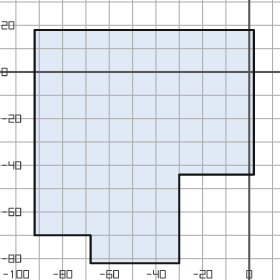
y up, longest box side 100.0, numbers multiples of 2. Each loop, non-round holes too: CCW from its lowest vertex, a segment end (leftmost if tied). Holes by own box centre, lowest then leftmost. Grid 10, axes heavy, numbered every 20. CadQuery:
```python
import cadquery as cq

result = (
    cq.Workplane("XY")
    .moveTo(-68.0, -82.0)
    .lineTo(-30.0, -82.0)
    .lineTo(-30.0, -44.0)
    .lineTo(2.0, -44.0)
    .lineTo(2.0, 18.0)
    .lineTo(-92.0, 18.0)
    .lineTo(-92.0, -70.0)
    .lineTo(-68.0, -70.0)
    .close()
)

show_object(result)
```